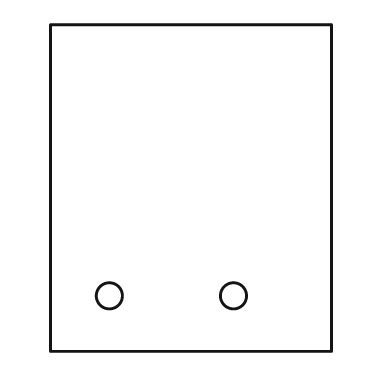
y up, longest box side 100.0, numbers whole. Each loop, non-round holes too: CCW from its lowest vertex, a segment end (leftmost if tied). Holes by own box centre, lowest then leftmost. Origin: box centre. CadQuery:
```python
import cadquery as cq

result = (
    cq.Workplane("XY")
    .moveTo(-43.0, -50.0)
    .lineTo(43.0, -50.0)
    .lineTo(43.0, 50.0)
    .lineTo(-43.0, 50.0)
    .close()
    .moveTo(-25.0, -33.0)
    .circle(4.0)
    .moveTo(13.0, -33.0)
    .circle(4.0)
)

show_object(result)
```